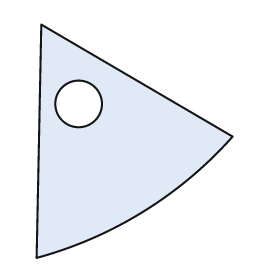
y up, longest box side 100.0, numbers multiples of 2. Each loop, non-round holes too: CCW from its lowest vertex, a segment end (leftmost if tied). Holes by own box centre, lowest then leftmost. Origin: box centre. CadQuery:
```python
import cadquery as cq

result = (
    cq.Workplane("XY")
    .moveTo(-42.0, -50.0)
    .threePointArc((4.0, -30.0), (42.0, 2.0))
    .lineTo(-40.0, 50.0)
    .close()
    .moveTo(-24.0, 16.0)
    .circle(10.0)
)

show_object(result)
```